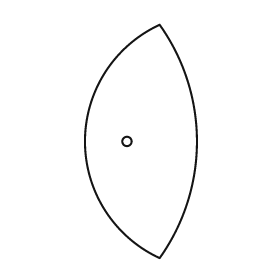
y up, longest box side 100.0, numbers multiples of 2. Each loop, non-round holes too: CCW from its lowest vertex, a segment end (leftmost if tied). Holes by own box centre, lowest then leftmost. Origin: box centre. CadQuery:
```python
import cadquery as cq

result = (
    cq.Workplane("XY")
    .moveTo(8.0, -50.0)
    .threePointArc((24.0, 0.0), (8.0, 50.0))
    .threePointArc((-24.0, 0.0), (8.0, -50.0))
    .close()
    .moveTo(-6.0, 0.0)
    .circle(2.0)
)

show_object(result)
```